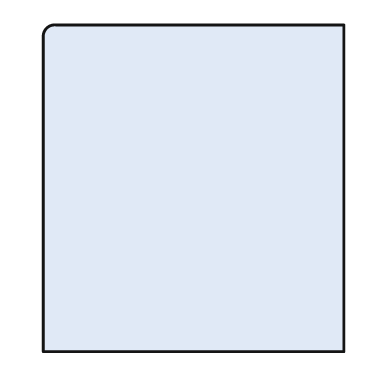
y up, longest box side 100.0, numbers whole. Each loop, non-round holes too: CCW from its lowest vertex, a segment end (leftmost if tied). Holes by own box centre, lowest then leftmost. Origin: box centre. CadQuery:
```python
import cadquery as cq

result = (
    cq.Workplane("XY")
    .moveTo(-46.0, -50.0)
    .lineTo(46.0, -50.0)
    .lineTo(46.0, 50.0)
    .lineTo(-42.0, 50.0)
    .threePointArc((-45.0, 49.0), (-46.0, 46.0))
    .close()
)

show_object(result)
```